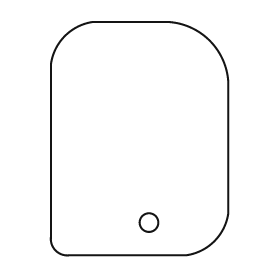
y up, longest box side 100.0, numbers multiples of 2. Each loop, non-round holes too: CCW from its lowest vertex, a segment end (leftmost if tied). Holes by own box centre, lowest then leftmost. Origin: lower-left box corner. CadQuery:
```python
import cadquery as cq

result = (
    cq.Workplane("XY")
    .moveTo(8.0, 0.0)
    .lineTo(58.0, 0.0)
    .threePointArc((70.0, 6.0), (76.0, 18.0))
    .lineTo(76.0, 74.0)
    .threePointArc((68.0, 92.0), (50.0, 100.0))
    .lineTo(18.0, 100.0)
    .threePointArc((6.0, 94.0), (0.0, 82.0))
    .lineTo(0.0, 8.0)
    .threePointArc((2.0, 2.0), (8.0, 0.0))
    .close()
    .moveTo(42.0, 14.0)
    .circle(4.0)
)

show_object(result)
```